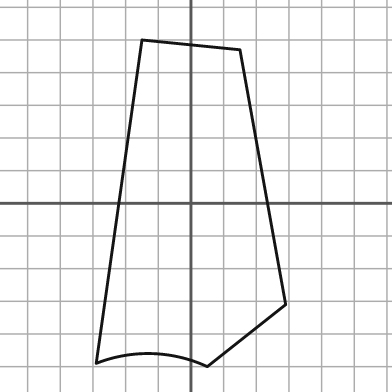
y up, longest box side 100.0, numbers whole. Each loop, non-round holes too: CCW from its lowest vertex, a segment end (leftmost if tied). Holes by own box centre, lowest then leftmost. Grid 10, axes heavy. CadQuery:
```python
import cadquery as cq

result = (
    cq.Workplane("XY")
    .moveTo(5.0, -50.0)
    .lineTo(29.0, -31.0)
    .lineTo(15.0, 47.0)
    .lineTo(-15.0, 50.0)
    .lineTo(-29.0, -49.0)
    .threePointArc((-12.0, -46.0), (5.0, -50.0))
    .close()
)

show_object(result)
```